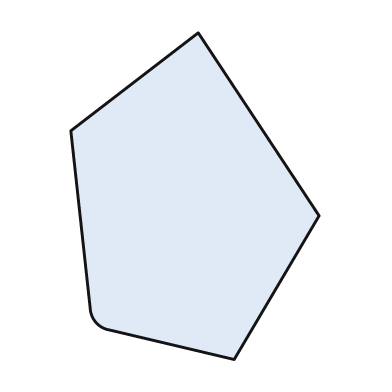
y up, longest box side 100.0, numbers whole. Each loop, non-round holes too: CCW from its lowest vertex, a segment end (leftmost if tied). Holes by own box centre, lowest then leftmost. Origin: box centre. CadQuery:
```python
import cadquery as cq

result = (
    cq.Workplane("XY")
    .moveTo(12.0, -50.0)
    .lineTo(38.0, -6.0)
    .lineTo(1.0, 50.0)
    .lineTo(-38.0, 20.0)
    .lineTo(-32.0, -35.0)
    .threePointArc((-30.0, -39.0), (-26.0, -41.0))
    .close()
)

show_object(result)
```